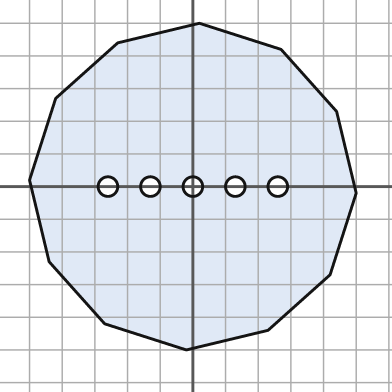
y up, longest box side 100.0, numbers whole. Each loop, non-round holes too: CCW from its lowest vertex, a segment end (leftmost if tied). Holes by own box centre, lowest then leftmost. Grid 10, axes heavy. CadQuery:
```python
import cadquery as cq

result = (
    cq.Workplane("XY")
    .moveTo(-2.0, -50.0)
    .lineTo(23.0, -44.0)
    .lineTo(42.0, -27.0)
    .lineTo(50.0, -2.0)
    .lineTo(44.0, 23.0)
    .lineTo(27.0, 42.0)
    .lineTo(2.0, 50.0)
    .lineTo(-23.0, 44.0)
    .lineTo(-42.0, 27.0)
    .lineTo(-50.0, 2.0)
    .lineTo(-44.0, -23.0)
    .lineTo(-27.0, -42.0)
    .close()
    .moveTo(-26.0, 0.0)
    .circle(3.0)
    .moveTo(-13.0, 0.0)
    .circle(3.0)
    .moveTo(0.0, 0.0)
    .circle(3.0)
    .moveTo(13.0, 0.0)
    .circle(3.0)
    .moveTo(26.0, 0.0)
    .circle(3.0)
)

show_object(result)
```